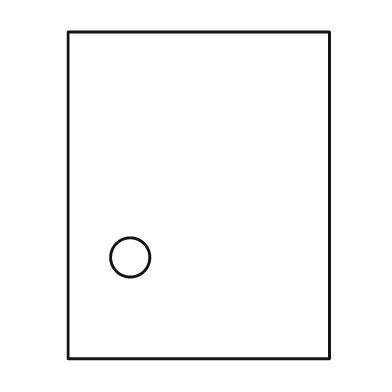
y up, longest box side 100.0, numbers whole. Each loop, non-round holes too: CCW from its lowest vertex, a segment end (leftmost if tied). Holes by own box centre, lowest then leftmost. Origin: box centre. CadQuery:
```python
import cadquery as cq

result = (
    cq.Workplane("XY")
    .moveTo(-40.0, -50.0)
    .lineTo(40.0, -50.0)
    .lineTo(40.0, 50.0)
    .lineTo(-40.0, 50.0)
    .close()
    .moveTo(-21.0, -19.0)
    .circle(6.0)
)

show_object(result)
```